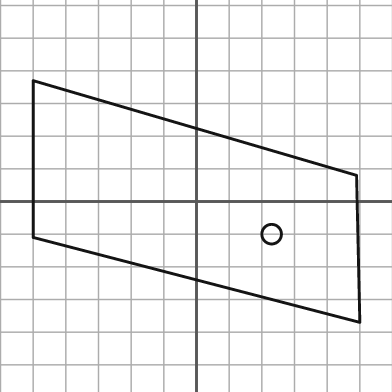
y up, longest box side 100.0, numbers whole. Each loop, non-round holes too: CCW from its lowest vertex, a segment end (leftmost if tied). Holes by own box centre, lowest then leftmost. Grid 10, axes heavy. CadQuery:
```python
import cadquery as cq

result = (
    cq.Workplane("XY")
    .moveTo(50.0, -37.0)
    .lineTo(49.0, 8.0)
    .lineTo(-50.0, 37.0)
    .lineTo(-50.0, -11.0)
    .close()
    .moveTo(23.0, -10.0)
    .circle(3.0)
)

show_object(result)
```